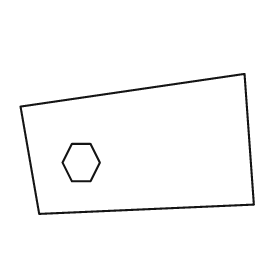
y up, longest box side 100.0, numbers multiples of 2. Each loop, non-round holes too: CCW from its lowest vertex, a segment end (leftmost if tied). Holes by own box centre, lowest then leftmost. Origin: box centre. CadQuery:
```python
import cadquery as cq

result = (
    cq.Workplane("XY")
    .moveTo(-42.0, -30.0)
    .lineTo(50.0, -26.0)
    .lineTo(46.0, 30.0)
    .lineTo(-50.0, 16.0)
    .close()
    .moveTo(-28.0, -16.0)
    .lineTo(-20.0, -16.0)
    .lineTo(-16.0, -8.0)
    .lineTo(-20.0, 0.0)
    .lineTo(-28.0, 0.0)
    .lineTo(-32.0, -8.0)
    .close()
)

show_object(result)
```